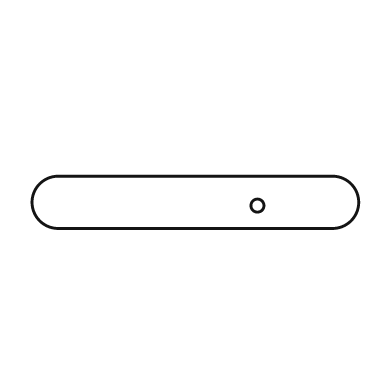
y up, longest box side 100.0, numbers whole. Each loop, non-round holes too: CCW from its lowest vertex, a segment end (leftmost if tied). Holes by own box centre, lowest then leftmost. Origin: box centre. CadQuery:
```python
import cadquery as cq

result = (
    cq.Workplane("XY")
    .moveTo(-42.0, -8.0)
    .lineTo(42.0, -8.0)
    .threePointArc((50.0, 0.0), (42.0, 8.0))
    .lineTo(-42.0, 8.0)
    .threePointArc((-50.0, 0.0), (-42.0, -8.0))
    .close()
    .moveTo(19.0, -1.0)
    .circle(2.0)
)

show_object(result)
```